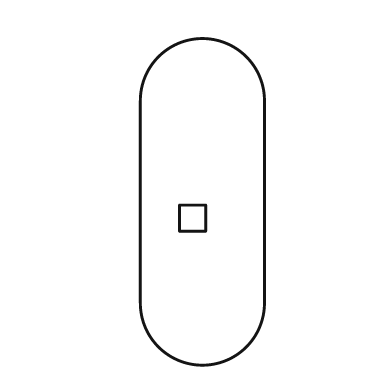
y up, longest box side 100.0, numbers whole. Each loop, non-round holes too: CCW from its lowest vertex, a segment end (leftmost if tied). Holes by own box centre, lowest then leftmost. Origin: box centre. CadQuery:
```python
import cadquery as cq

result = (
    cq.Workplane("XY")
    .moveTo(-19.0, -31.0)
    .threePointArc((0.0, -50.0), (19.0, -31.0))
    .lineTo(19.0, 31.0)
    .threePointArc((0.0, 50.0), (-19.0, 31.0))
    .close()
    .moveTo(-7.0, -9.0)
    .lineTo(1.0, -9.0)
    .lineTo(1.0, -1.0)
    .lineTo(-7.0, -1.0)
    .close()
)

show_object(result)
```